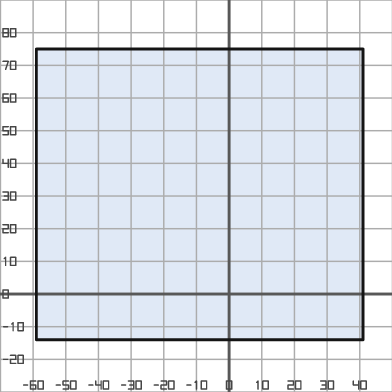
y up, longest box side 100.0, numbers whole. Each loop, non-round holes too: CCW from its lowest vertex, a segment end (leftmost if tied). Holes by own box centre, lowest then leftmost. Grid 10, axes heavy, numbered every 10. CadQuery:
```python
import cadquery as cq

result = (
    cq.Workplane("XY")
    .moveTo(-59.0, -14.0)
    .lineTo(41.0, -14.0)
    .lineTo(41.0, 75.0)
    .lineTo(-59.0, 75.0)
    .close()
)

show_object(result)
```